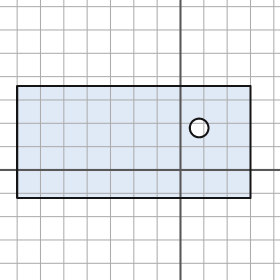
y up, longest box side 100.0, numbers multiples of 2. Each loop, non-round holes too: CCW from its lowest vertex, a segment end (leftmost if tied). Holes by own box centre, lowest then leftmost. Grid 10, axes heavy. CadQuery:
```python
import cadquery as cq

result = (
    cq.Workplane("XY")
    .moveTo(-70.0, -12.0)
    .lineTo(30.0, -12.0)
    .lineTo(30.0, 36.0)
    .lineTo(-70.0, 36.0)
    .close()
    .moveTo(8.0, 18.0)
    .circle(4.0)
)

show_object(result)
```